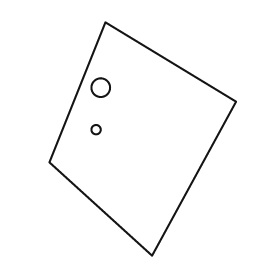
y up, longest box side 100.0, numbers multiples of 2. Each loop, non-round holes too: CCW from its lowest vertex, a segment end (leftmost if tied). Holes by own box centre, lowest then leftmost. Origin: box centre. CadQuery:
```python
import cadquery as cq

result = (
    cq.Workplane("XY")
    .moveTo(4.0, -50.0)
    .lineTo(40.0, 16.0)
    .lineTo(-16.0, 50.0)
    .lineTo(-40.0, -10.0)
    .close()
    .moveTo(-20.0, 4.0)
    .circle(2.0)
    .moveTo(-18.0, 22.0)
    .circle(4.0)
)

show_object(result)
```